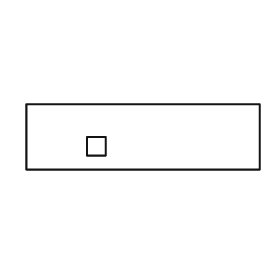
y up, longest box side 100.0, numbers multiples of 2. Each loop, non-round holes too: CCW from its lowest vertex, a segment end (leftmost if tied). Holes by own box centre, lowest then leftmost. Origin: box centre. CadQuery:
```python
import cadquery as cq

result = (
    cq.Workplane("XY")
    .moveTo(-50.0, -14.0)
    .lineTo(50.0, -14.0)
    .lineTo(50.0, 14.0)
    .lineTo(-50.0, 14.0)
    .close()
    .moveTo(-24.0, -8.0)
    .lineTo(-16.0, -8.0)
    .lineTo(-16.0, 0.0)
    .lineTo(-24.0, 0.0)
    .close()
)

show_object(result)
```